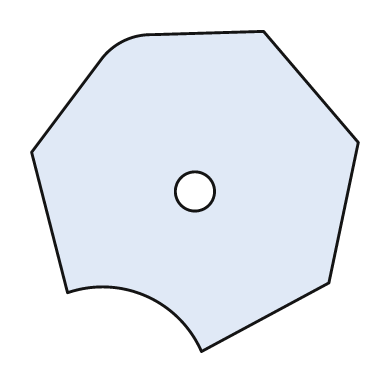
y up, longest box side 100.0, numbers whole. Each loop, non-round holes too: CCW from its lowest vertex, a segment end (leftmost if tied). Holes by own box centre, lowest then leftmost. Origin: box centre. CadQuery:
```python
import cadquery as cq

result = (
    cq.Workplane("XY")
    .moveTo(2.0, -49.0)
    .lineTo(41.0, -28.0)
    .lineTo(50.0, 15.0)
    .lineTo(21.0, 49.0)
    .lineTo(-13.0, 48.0)
    .threePointArc((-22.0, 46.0), (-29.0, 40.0))
    .lineTo(-50.0, 12.0)
    .lineTo(-39.0, -31.0)
    .threePointArc((-15.0, -32.0), (2.0, -49.0))
    .close()
    .moveTo(0.0, 0.0)
    .circle(6.0)
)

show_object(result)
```